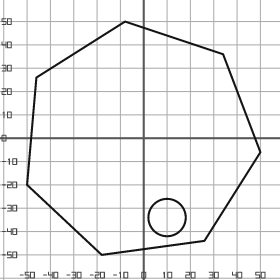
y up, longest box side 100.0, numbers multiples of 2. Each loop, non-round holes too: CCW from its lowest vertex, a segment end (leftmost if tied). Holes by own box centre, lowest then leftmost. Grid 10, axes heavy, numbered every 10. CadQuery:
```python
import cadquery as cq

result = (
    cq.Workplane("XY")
    .moveTo(-18.0, -50.0)
    .lineTo(26.0, -44.0)
    .lineTo(50.0, -6.0)
    .lineTo(34.0, 36.0)
    .lineTo(-8.0, 50.0)
    .lineTo(-46.0, 26.0)
    .lineTo(-50.0, -20.0)
    .close()
    .moveTo(10.0, -34.0)
    .circle(8.0)
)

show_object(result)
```